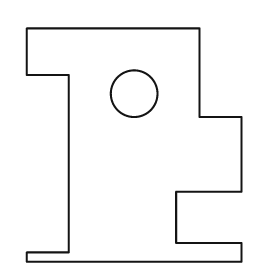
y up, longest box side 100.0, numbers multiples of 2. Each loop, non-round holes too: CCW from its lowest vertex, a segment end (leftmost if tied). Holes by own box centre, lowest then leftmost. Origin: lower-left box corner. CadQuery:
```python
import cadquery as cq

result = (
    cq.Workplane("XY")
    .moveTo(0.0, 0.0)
    .lineTo(92.0, 0.0)
    .lineTo(92.0, 8.0)
    .lineTo(64.0, 8.0)
    .lineTo(64.0, 30.0)
    .lineTo(92.0, 30.0)
    .lineTo(92.0, 62.0)
    .lineTo(74.0, 62.0)
    .lineTo(74.0, 100.0)
    .lineTo(0.0, 100.0)
    .lineTo(0.0, 80.0)
    .lineTo(18.0, 80.0)
    .lineTo(18.0, 4.0)
    .lineTo(0.0, 4.0)
    .close()
    .moveTo(46.0, 72.0)
    .circle(10.0)
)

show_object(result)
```